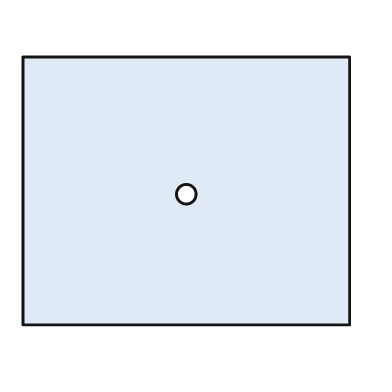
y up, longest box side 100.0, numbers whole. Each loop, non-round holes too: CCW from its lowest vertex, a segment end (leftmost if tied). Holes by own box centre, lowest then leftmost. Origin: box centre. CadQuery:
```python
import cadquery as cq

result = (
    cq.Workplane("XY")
    .moveTo(-50.0, -41.0)
    .lineTo(50.0, -41.0)
    .lineTo(50.0, 41.0)
    .lineTo(-50.0, 41.0)
    .close()
    .moveTo(0.0, -1.0)
    .circle(3.0)
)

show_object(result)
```